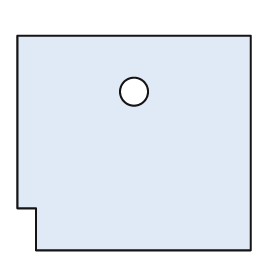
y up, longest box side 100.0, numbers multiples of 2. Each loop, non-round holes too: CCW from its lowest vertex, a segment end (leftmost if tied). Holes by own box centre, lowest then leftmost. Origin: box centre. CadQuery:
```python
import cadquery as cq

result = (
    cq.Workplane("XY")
    .moveTo(-42.0, -46.0)
    .lineTo(50.0, -46.0)
    .lineTo(50.0, 46.0)
    .lineTo(-50.0, 46.0)
    .lineTo(-50.0, -28.0)
    .lineTo(-42.0, -28.0)
    .close()
    .moveTo(0.0, 22.0)
    .circle(6.0)
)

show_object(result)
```